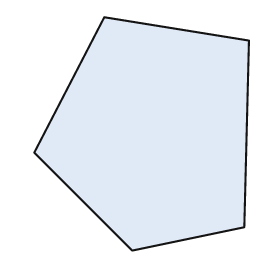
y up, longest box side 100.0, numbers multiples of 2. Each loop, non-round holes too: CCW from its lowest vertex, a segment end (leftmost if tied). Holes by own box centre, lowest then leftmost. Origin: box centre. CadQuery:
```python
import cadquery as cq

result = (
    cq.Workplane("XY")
    .moveTo(-4.0, -50.0)
    .lineTo(44.0, -40.0)
    .lineTo(46.0, 40.0)
    .lineTo(-16.0, 50.0)
    .lineTo(-46.0, -8.0)
    .close()
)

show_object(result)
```